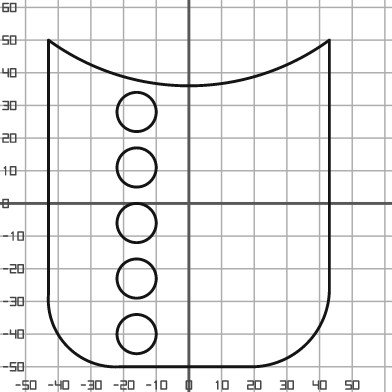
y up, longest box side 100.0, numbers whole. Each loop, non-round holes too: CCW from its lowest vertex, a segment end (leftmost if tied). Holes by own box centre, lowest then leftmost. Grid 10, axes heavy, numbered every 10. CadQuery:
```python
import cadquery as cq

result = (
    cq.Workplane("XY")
    .moveTo(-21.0, -50.0)
    .lineTo(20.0, -50.0)
    .threePointArc((36.0, -43.0), (43.0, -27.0))
    .lineTo(43.0, 50.0)
    .threePointArc((0.0, 36.0), (-43.0, 50.0))
    .lineTo(-43.0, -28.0)
    .threePointArc((-37.0, -44.0), (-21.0, -50.0))
    .close()
    .moveTo(-16.0, -40.0)
    .circle(6.0)
    .moveTo(-16.0, -23.0)
    .circle(6.0)
    .moveTo(-16.0, -6.0)
    .circle(6.0)
    .moveTo(-16.0, 11.0)
    .circle(6.0)
    .moveTo(-16.0, 28.0)
    .circle(6.0)
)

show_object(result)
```